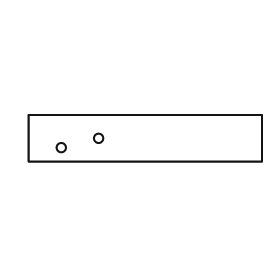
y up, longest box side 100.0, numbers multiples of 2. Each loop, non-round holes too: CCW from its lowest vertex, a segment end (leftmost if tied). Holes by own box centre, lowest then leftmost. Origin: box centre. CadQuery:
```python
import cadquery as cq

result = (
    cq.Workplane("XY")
    .moveTo(-50.0, -10.0)
    .lineTo(50.0, -10.0)
    .lineTo(50.0, 10.0)
    .lineTo(-50.0, 10.0)
    .close()
    .moveTo(-36.0, -4.0)
    .circle(2.0)
    .moveTo(-20.0, 0.0)
    .circle(2.0)
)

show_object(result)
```